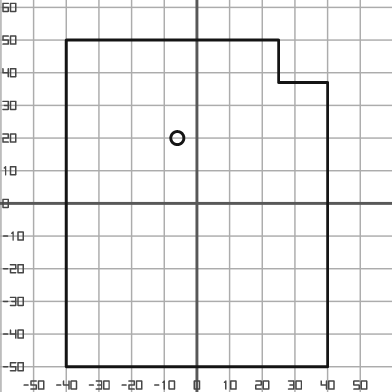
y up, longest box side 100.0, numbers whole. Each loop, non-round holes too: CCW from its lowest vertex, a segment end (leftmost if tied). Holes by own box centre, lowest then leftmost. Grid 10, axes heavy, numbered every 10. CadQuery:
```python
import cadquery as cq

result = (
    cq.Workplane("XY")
    .moveTo(-40.0, -50.0)
    .lineTo(40.0, -50.0)
    .lineTo(40.0, 37.0)
    .lineTo(25.0, 37.0)
    .lineTo(25.0, 50.0)
    .lineTo(-40.0, 50.0)
    .close()
    .moveTo(-6.0, 20.0)
    .circle(2.0)
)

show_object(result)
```